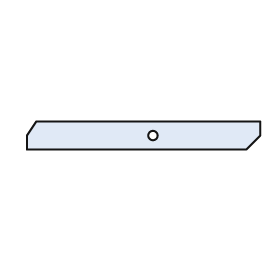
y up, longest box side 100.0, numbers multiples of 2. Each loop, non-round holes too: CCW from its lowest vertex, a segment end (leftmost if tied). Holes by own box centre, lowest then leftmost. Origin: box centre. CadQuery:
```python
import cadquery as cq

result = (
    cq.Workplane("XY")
    .moveTo(-50.0, -6.0)
    .lineTo(44.0, -6.0)
    .lineTo(50.0, 0.0)
    .lineTo(50.0, 6.0)
    .lineTo(-46.0, 6.0)
    .lineTo(-50.0, 0.0)
    .close()
    .moveTo(4.0, 0.0)
    .circle(2.0)
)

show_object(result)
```